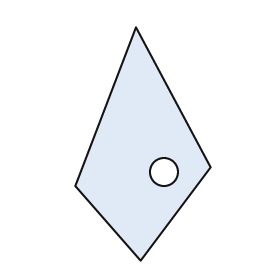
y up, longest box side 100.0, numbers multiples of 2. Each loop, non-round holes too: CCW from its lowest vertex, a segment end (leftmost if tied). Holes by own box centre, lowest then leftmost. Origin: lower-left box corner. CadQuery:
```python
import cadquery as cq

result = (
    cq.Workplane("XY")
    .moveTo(28.0, 0.0)
    .lineTo(58.0, 40.0)
    .lineTo(26.0, 100.0)
    .lineTo(0.0, 32.0)
    .close()
    .moveTo(38.0, 38.0)
    .circle(6.0)
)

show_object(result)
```